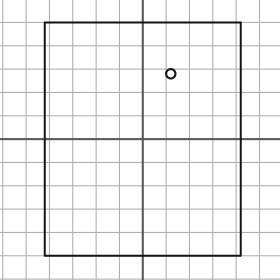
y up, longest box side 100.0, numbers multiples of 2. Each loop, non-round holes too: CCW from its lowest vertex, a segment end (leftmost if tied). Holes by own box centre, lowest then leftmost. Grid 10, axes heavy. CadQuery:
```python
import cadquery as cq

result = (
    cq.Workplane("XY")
    .moveTo(-42.0, -50.0)
    .lineTo(42.0, -50.0)
    .lineTo(42.0, 50.0)
    .lineTo(-42.0, 50.0)
    .close()
    .moveTo(12.0, 28.0)
    .circle(2.0)
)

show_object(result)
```